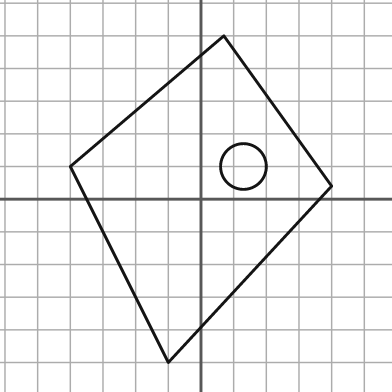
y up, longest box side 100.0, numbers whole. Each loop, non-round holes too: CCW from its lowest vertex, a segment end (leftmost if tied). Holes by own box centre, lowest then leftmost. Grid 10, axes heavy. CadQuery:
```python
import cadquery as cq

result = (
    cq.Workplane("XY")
    .moveTo(-10.0, -50.0)
    .lineTo(40.0, 4.0)
    .lineTo(7.0, 50.0)
    .lineTo(-40.0, 10.0)
    .close()
    .moveTo(13.0, 10.0)
    .circle(7.0)
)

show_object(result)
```